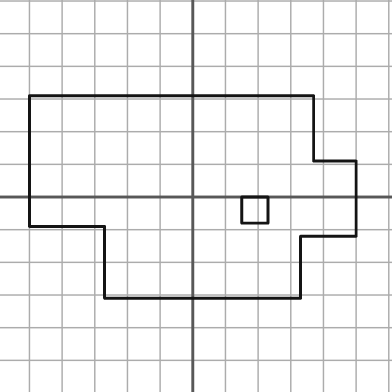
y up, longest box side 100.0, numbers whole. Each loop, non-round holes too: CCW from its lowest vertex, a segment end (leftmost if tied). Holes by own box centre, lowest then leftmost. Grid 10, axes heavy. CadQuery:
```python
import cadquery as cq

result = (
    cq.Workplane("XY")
    .moveTo(-27.0, -31.0)
    .lineTo(33.0, -31.0)
    .lineTo(33.0, -12.0)
    .lineTo(50.0, -12.0)
    .lineTo(50.0, 11.0)
    .lineTo(37.0, 11.0)
    .lineTo(37.0, 31.0)
    .lineTo(-50.0, 31.0)
    .lineTo(-50.0, -9.0)
    .lineTo(-27.0, -9.0)
    .close()
    .moveTo(15.0, -8.0)
    .lineTo(23.0, -8.0)
    .lineTo(23.0, 0.0)
    .lineTo(15.0, 0.0)
    .close()
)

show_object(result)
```